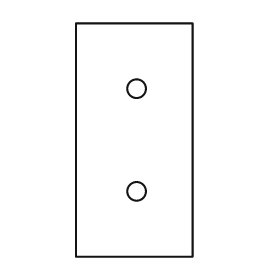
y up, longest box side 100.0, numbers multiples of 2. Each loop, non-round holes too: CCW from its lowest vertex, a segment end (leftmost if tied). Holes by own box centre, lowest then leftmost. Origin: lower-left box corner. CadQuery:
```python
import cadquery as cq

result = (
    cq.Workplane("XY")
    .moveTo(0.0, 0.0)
    .lineTo(50.0, 0.0)
    .lineTo(50.0, 100.0)
    .lineTo(0.0, 100.0)
    .close()
    .moveTo(26.0, 28.0)
    .circle(4.0)
    .moveTo(26.0, 72.0)
    .circle(4.0)
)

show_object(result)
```